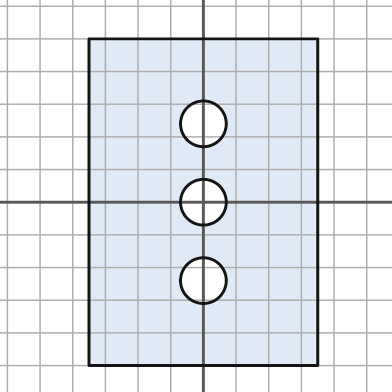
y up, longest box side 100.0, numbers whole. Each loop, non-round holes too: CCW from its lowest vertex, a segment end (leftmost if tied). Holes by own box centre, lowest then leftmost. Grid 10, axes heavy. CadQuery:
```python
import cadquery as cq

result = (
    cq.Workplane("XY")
    .moveTo(-35.0, -50.0)
    .lineTo(35.0, -50.0)
    .lineTo(35.0, 50.0)
    .lineTo(-35.0, 50.0)
    .close()
    .moveTo(0.0, -24.0)
    .circle(7.0)
    .moveTo(0.0, 0.0)
    .circle(7.0)
    .moveTo(0.0, 24.0)
    .circle(7.0)
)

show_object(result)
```